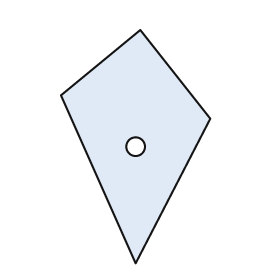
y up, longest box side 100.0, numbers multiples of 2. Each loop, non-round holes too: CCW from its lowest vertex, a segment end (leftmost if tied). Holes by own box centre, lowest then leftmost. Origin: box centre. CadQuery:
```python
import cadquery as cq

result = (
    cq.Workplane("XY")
    .moveTo(0.0, -50.0)
    .lineTo(32.0, 12.0)
    .lineTo(2.0, 50.0)
    .lineTo(-32.0, 22.0)
    .close()
    .moveTo(0.0, 0.0)
    .circle(4.0)
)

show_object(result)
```